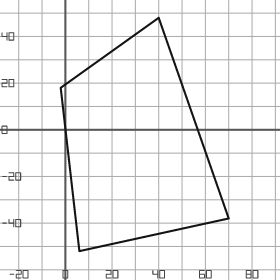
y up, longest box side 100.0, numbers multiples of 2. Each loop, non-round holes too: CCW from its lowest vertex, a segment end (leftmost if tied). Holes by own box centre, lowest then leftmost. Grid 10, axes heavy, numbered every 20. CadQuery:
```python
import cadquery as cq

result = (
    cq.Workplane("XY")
    .moveTo(6.0, -52.0)
    .lineTo(70.0, -38.0)
    .lineTo(40.0, 48.0)
    .lineTo(-2.0, 18.0)
    .close()
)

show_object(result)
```